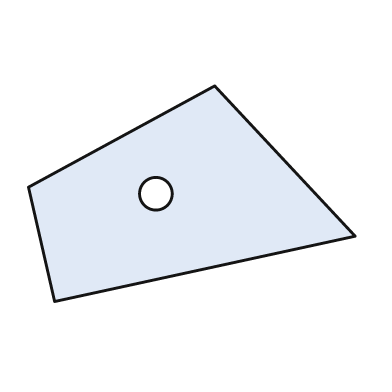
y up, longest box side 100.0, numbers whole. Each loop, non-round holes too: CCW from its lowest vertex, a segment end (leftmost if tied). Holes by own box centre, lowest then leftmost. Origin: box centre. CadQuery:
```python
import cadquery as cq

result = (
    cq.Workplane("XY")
    .moveTo(-42.0, -33.0)
    .lineTo(50.0, -13.0)
    .lineTo(7.0, 33.0)
    .lineTo(-50.0, 2.0)
    .close()
    .moveTo(-11.0, 0.0)
    .circle(5.0)
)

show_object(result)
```